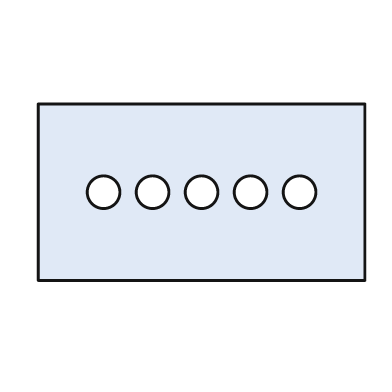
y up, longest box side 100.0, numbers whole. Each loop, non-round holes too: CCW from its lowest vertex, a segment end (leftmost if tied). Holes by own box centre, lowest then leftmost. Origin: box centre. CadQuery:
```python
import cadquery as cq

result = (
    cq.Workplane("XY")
    .moveTo(-50.0, -27.0)
    .lineTo(50.0, -27.0)
    .lineTo(50.0, 27.0)
    .lineTo(-50.0, 27.0)
    .close()
    .moveTo(-30.0, 0.0)
    .circle(5.0)
    .moveTo(-15.0, 0.0)
    .circle(5.0)
    .moveTo(0.0, 0.0)
    .circle(5.0)
    .moveTo(15.0, 0.0)
    .circle(5.0)
    .moveTo(30.0, 0.0)
    .circle(5.0)
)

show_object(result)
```